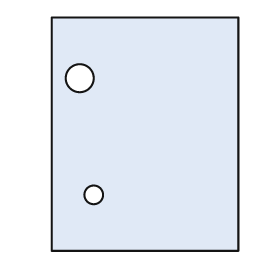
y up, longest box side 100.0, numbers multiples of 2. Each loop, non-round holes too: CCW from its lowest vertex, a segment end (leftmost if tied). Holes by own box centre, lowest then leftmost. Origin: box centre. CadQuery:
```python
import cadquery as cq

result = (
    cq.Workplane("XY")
    .moveTo(-40.0, -50.0)
    .lineTo(40.0, -50.0)
    .lineTo(40.0, 50.0)
    .lineTo(-40.0, 50.0)
    .close()
    .moveTo(-22.0, -26.0)
    .circle(4.0)
    .moveTo(-28.0, 24.0)
    .circle(6.0)
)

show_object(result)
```